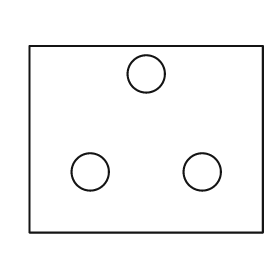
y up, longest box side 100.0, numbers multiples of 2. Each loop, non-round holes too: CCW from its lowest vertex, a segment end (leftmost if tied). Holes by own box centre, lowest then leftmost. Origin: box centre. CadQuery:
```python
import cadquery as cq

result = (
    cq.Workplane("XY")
    .moveTo(-50.0, -40.0)
    .lineTo(50.0, -40.0)
    .lineTo(50.0, 40.0)
    .lineTo(-50.0, 40.0)
    .close()
    .moveTo(-24.0, -14.0)
    .circle(8.0)
    .moveTo(24.0, -14.0)
    .circle(8.0)
    .moveTo(0.0, 28.0)
    .circle(8.0)
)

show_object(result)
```